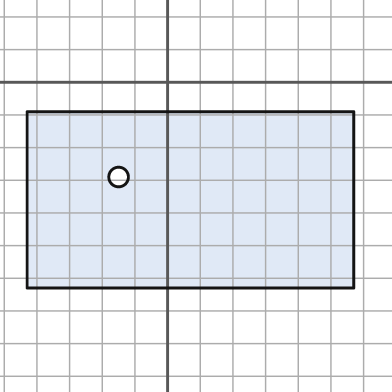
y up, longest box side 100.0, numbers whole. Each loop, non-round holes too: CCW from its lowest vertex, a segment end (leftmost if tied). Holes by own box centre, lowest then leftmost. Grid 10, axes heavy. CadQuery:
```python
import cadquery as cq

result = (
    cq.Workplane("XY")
    .moveTo(-43.0, -63.0)
    .lineTo(57.0, -63.0)
    .lineTo(57.0, -9.0)
    .lineTo(-43.0, -9.0)
    .close()
    .moveTo(-15.0, -29.0)
    .circle(3.0)
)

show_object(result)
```